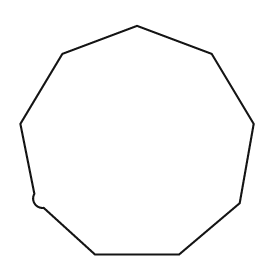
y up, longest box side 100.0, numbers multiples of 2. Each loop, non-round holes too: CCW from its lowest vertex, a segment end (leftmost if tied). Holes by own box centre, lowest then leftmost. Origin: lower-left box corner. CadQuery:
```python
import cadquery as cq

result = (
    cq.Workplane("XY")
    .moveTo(32.0, 0.0)
    .lineTo(68.0, 0.0)
    .lineTo(94.0, 22.0)
    .lineTo(100.0, 56.0)
    .lineTo(82.0, 86.0)
    .lineTo(50.0, 98.0)
    .lineTo(18.0, 86.0)
    .lineTo(0.0, 56.0)
    .lineTo(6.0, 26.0)
    .threePointArc((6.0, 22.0), (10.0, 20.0))
    .close()
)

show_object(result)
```